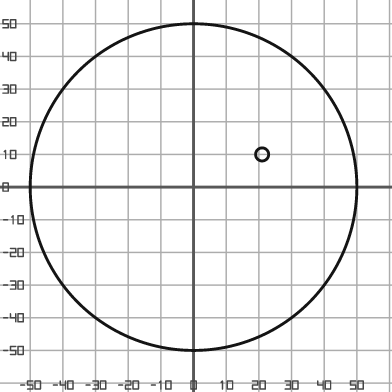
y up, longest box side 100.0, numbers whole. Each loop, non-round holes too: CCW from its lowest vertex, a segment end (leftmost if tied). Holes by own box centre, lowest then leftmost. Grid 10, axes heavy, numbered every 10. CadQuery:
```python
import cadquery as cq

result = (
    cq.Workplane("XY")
    .moveTo(0.0, 0.0)
    .circle(50.0)
    .moveTo(21.0, 10.0)
    .circle(2.0)
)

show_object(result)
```